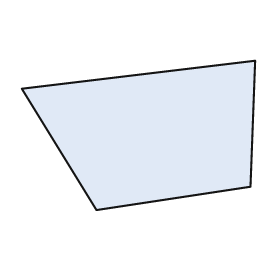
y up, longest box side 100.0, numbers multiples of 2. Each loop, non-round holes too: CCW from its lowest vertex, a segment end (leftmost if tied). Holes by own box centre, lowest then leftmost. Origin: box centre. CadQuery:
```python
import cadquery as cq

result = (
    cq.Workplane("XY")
    .moveTo(-18.0, -32.0)
    .lineTo(48.0, -22.0)
    .lineTo(50.0, 32.0)
    .lineTo(-50.0, 20.0)
    .close()
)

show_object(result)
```